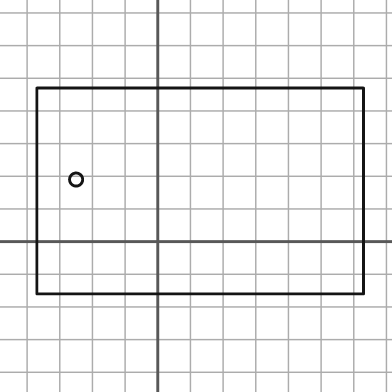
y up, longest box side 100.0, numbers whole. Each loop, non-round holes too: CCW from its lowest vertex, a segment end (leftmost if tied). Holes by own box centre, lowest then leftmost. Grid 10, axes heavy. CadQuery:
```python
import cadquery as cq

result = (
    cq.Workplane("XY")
    .moveTo(-37.0, -16.0)
    .lineTo(63.0, -16.0)
    .lineTo(63.0, 47.0)
    .lineTo(-37.0, 47.0)
    .close()
    .moveTo(-25.0, 19.0)
    .circle(2.0)
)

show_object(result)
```